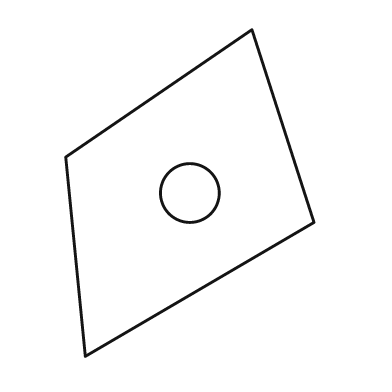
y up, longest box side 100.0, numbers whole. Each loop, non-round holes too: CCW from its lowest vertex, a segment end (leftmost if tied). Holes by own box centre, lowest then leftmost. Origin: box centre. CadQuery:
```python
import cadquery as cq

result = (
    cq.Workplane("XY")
    .moveTo(-32.0, -50.0)
    .lineTo(38.0, -9.0)
    .lineTo(19.0, 50.0)
    .lineTo(-38.0, 11.0)
    .close()
    .moveTo(0.0, 0.0)
    .circle(9.0)
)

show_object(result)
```